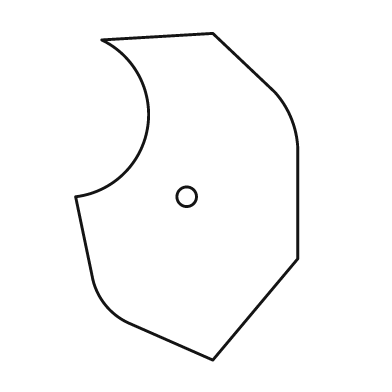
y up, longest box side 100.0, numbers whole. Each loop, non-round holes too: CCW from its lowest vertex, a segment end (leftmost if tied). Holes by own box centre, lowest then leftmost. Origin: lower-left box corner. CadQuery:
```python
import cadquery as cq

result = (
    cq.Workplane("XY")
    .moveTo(42.0, 0.0)
    .lineTo(68.0, 31.0)
    .lineTo(68.0, 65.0)
    .threePointArc((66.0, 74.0), (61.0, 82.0))
    .lineTo(42.0, 100.0)
    .lineTo(8.0, 98.0)
    .threePointArc((22.0, 71.0), (0.0, 50.0))
    .lineTo(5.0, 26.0)
    .threePointArc((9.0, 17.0), (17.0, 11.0))
    .close()
    .moveTo(34.0, 50.0)
    .circle(3.0)
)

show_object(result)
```